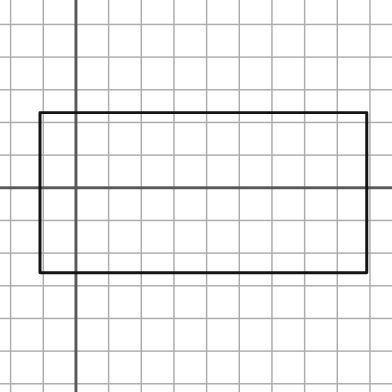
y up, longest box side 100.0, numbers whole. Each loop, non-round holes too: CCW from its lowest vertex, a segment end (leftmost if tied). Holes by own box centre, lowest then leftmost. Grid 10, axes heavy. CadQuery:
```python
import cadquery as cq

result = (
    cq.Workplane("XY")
    .moveTo(-11.0, -26.0)
    .lineTo(89.0, -26.0)
    .lineTo(89.0, 23.0)
    .lineTo(-11.0, 23.0)
    .close()
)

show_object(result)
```